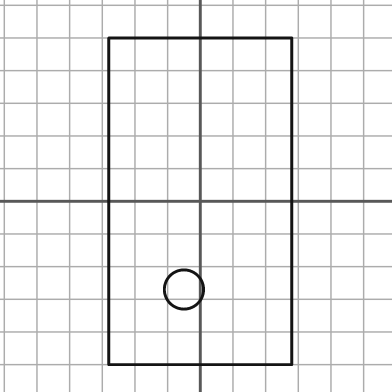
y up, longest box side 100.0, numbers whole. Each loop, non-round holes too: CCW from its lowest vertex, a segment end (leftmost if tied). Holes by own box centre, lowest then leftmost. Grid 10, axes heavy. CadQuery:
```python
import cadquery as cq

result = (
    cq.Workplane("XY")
    .moveTo(-28.0, -50.0)
    .lineTo(28.0, -50.0)
    .lineTo(28.0, 50.0)
    .lineTo(-28.0, 50.0)
    .close()
    .moveTo(-5.0, -27.0)
    .circle(6.0)
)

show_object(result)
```